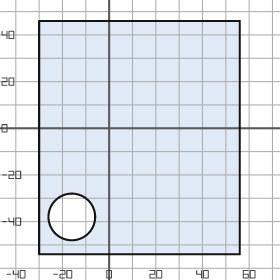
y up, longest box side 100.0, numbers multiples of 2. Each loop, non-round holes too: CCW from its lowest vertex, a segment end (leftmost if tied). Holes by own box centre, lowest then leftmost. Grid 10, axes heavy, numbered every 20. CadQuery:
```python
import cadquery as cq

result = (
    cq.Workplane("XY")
    .moveTo(-30.0, -54.0)
    .lineTo(56.0, -54.0)
    .lineTo(56.0, 46.0)
    .lineTo(-30.0, 46.0)
    .close()
    .moveTo(-16.0, -38.0)
    .circle(10.0)
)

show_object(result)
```